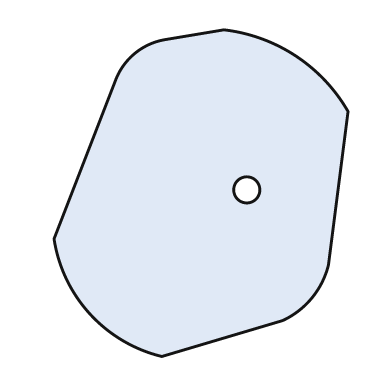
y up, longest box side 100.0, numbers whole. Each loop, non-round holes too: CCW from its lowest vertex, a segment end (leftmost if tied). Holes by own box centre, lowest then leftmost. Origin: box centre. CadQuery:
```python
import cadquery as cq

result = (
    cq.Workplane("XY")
    .moveTo(-12.0, -50.0)
    .lineTo(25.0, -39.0)
    .threePointArc((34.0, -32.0), (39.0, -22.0))
    .lineTo(45.0, 25.0)
    .threePointArc((29.0, 42.0), (7.0, 50.0))
    .lineTo(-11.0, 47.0)
    .threePointArc((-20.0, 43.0), (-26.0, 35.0))
    .lineTo(-45.0, -14.0)
    .threePointArc((-34.0, -37.0), (-12.0, -50.0))
    .close()
    .moveTo(14.0, 1.0)
    .circle(4.0)
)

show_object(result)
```